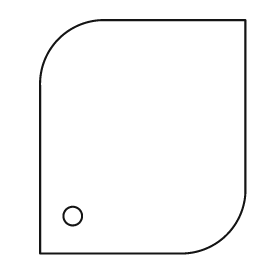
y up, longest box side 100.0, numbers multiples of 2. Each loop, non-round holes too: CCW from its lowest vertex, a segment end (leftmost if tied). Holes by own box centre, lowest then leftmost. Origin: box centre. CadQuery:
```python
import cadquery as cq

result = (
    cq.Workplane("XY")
    .moveTo(-44.0, -50.0)
    .lineTo(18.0, -50.0)
    .threePointArc((36.0, -42.0), (44.0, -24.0))
    .lineTo(44.0, 50.0)
    .lineTo(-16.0, 50.0)
    .threePointArc((-36.0, 42.0), (-44.0, 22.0))
    .close()
    .moveTo(-30.0, -34.0)
    .circle(4.0)
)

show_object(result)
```